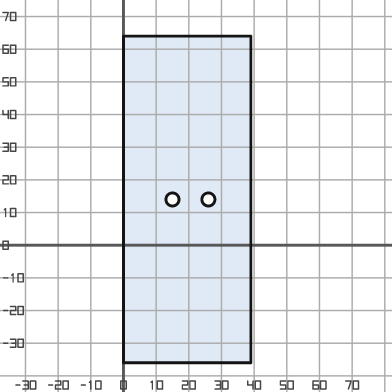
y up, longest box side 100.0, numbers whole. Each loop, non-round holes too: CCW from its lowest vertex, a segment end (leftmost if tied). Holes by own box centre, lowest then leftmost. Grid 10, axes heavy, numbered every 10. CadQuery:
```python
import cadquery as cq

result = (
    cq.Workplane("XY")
    .moveTo(0.0, -36.0)
    .lineTo(39.0, -36.0)
    .lineTo(39.0, 64.0)
    .lineTo(0.0, 64.0)
    .close()
    .moveTo(15.0, 14.0)
    .circle(2.0)
    .moveTo(26.0, 14.0)
    .circle(2.0)
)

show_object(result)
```